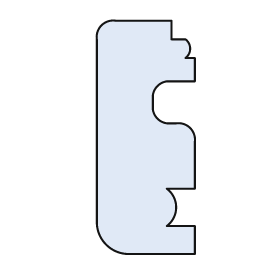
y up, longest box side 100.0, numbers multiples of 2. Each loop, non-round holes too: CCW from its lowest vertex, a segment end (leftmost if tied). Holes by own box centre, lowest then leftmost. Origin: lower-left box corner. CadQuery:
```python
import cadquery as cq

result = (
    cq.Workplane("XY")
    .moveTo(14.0, 0.0)
    .lineTo(42.0, 0.0)
    .lineTo(42.0, 12.0)
    .lineTo(30.0, 12.0)
    .threePointArc((34.0, 20.0), (30.0, 28.0))
    .lineTo(42.0, 28.0)
    .lineTo(42.0, 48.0)
    .threePointArc((40.0, 54.0), (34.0, 56.0))
    .lineTo(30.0, 56.0)
    .threePointArc((26.0, 58.0), (24.0, 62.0))
    .lineTo(24.0, 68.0)
    .threePointArc((26.0, 72.0), (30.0, 74.0))
    .lineTo(42.0, 74.0)
    .lineTo(42.0, 84.0)
    .lineTo(38.0, 84.0)
    .threePointArc((40.0, 88.0), (38.0, 92.0))
    .lineTo(32.0, 92.0)
    .lineTo(32.0, 100.0)
    .lineTo(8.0, 100.0)
    .threePointArc((2.0, 98.0), (0.0, 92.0))
    .lineTo(0.0, 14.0)
    .threePointArc((4.0, 4.0), (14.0, 0.0))
    .close()
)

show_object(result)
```